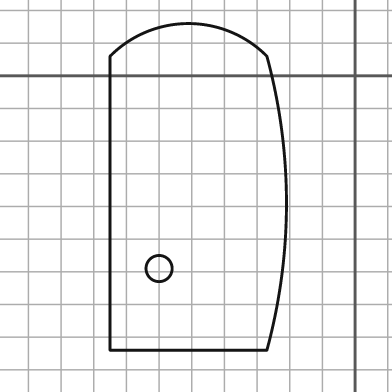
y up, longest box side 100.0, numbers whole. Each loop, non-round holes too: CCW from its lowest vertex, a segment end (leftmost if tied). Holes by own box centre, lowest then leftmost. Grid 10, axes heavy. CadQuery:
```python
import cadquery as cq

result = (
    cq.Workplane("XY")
    .moveTo(-75.0, -84.0)
    .lineTo(-27.0, -84.0)
    .threePointArc((-21.0, -39.0), (-27.0, 6.0))
    .threePointArc((-51.0, 16.0), (-75.0, 6.0))
    .close()
    .moveTo(-60.0, -59.0)
    .circle(4.0)
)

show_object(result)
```